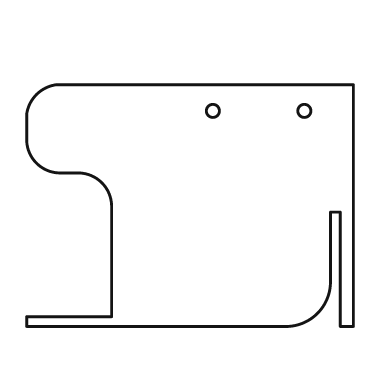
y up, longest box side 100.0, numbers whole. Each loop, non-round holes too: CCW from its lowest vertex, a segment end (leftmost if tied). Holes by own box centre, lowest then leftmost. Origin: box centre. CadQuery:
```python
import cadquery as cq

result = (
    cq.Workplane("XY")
    .moveTo(-50.0, -37.0)
    .lineTo(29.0, -37.0)
    .threePointArc((39.0, -33.0), (43.0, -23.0))
    .lineTo(43.0, -2.0)
    .lineTo(46.0, -2.0)
    .lineTo(46.0, -37.0)
    .lineTo(50.0, -37.0)
    .lineTo(50.0, 37.0)
    .lineTo(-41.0, 37.0)
    .threePointArc((-47.0, 34.0), (-50.0, 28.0))
    .lineTo(-50.0, 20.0)
    .threePointArc((-47.0, 13.0), (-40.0, 10.0))
    .lineTo(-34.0, 10.0)
    .threePointArc((-27.0, 7.0), (-24.0, 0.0))
    .lineTo(-24.0, -34.0)
    .lineTo(-50.0, -34.0)
    .close()
    .moveTo(7.0, 29.0)
    .circle(2.0)
    .moveTo(35.0, 29.0)
    .circle(2.0)
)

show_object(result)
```